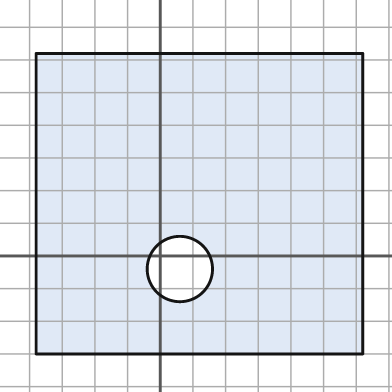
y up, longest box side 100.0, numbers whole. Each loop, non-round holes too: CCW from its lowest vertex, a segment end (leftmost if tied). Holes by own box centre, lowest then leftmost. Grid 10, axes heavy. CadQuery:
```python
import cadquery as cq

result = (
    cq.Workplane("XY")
    .moveTo(-38.0, -30.0)
    .lineTo(62.0, -30.0)
    .lineTo(62.0, 62.0)
    .lineTo(-38.0, 62.0)
    .close()
    .moveTo(6.0, -4.0)
    .circle(10.0)
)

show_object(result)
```